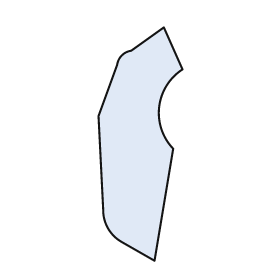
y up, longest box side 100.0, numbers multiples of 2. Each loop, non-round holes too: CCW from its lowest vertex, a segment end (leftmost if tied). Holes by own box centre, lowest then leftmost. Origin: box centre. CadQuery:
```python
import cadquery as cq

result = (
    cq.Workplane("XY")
    .moveTo(6.0, -50.0)
    .lineTo(14.0, -2.0)
    .threePointArc((8.0, 16.0), (18.0, 32.0))
    .lineTo(10.0, 50.0)
    .lineTo(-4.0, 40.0)
    .threePointArc((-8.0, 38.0), (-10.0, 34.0))
    .lineTo(-18.0, 12.0)
    .lineTo(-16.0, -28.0)
    .threePointArc((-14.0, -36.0), (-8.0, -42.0))
    .close()
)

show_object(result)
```